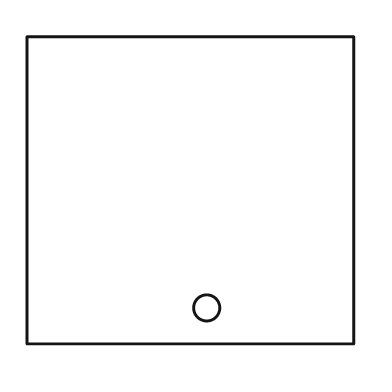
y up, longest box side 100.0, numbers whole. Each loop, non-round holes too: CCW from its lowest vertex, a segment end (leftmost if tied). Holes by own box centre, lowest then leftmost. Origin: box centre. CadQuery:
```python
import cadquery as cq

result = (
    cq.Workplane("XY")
    .moveTo(-50.0, -47.0)
    .lineTo(50.0, -47.0)
    .lineTo(50.0, 47.0)
    .lineTo(-50.0, 47.0)
    .close()
    .moveTo(5.0, -36.0)
    .circle(4.0)
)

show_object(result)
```